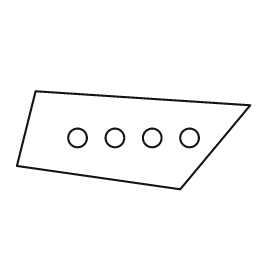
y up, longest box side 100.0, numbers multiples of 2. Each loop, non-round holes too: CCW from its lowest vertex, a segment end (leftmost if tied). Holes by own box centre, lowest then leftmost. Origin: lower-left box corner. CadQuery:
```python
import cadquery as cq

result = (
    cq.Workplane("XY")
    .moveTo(70.0, 0.0)
    .lineTo(100.0, 36.0)
    .lineTo(8.0, 42.0)
    .lineTo(0.0, 10.0)
    .close()
    .moveTo(26.0, 22.0)
    .circle(4.0)
    .moveTo(42.0, 22.0)
    .circle(4.0)
    .moveTo(58.0, 22.0)
    .circle(4.0)
    .moveTo(74.0, 22.0)
    .circle(4.0)
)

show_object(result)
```